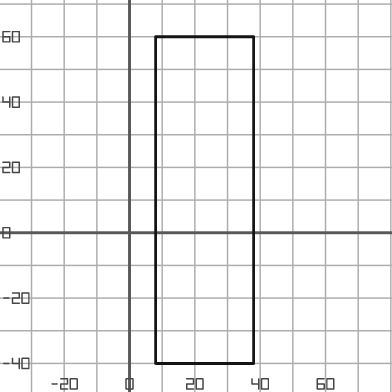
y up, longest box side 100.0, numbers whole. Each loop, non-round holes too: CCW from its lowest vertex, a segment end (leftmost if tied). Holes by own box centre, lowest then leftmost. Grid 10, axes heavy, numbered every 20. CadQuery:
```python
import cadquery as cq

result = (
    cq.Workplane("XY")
    .moveTo(8.0, -40.0)
    .lineTo(38.0, -40.0)
    .lineTo(38.0, 60.0)
    .lineTo(8.0, 60.0)
    .close()
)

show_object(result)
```